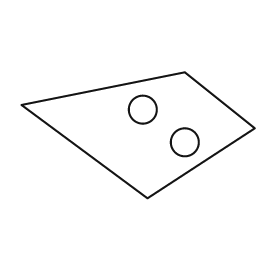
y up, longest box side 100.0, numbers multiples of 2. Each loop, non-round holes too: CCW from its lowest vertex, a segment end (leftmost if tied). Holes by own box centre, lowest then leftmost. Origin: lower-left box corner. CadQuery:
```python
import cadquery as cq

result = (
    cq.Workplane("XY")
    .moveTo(54.0, 0.0)
    .lineTo(100.0, 30.0)
    .lineTo(70.0, 54.0)
    .lineTo(0.0, 40.0)
    .close()
    .moveTo(70.0, 24.0)
    .circle(6.0)
    .moveTo(52.0, 38.0)
    .circle(6.0)
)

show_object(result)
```